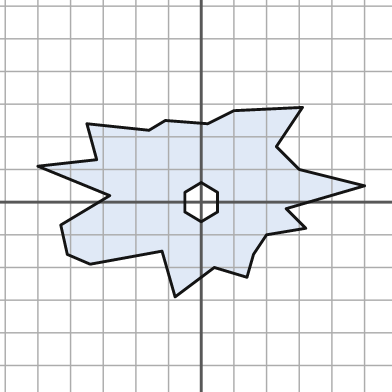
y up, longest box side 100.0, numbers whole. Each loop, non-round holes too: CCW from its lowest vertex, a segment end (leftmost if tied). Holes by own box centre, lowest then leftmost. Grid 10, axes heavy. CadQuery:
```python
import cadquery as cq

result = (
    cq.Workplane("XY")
    .moveTo(-8.0, -29.0)
    .lineTo(4.0, -20.0)
    .lineTo(14.0, -23.0)
    .lineTo(16.0, -16.0)
    .lineTo(20.0, -10.0)
    .lineTo(32.0, -8.0)
    .lineTo(26.0, -2.0)
    .lineTo(50.0, 5.0)
    .lineTo(30.0, 10.0)
    .lineTo(23.0, 17.0)
    .lineTo(31.0, 29.0)
    .lineTo(10.0, 28.0)
    .lineTo(2.0, 24.0)
    .lineTo(-11.0, 25.0)
    .lineTo(-16.0, 22.0)
    .lineTo(-35.0, 24.0)
    .lineTo(-32.0, 13.0)
    .lineTo(-50.0, 11.0)
    .lineTo(-28.0, 2.0)
    .lineTo(-43.0, -7.0)
    .lineTo(-41.0, -16.0)
    .lineTo(-34.0, -19.0)
    .lineTo(-12.0, -15.0)
    .close()
    .moveTo(0.0, -6.0)
    .lineTo(5.0, -3.0)
    .lineTo(5.0, 3.0)
    .lineTo(0.0, 6.0)
    .lineTo(-5.0, 3.0)
    .lineTo(-5.0, -3.0)
    .close()
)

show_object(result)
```